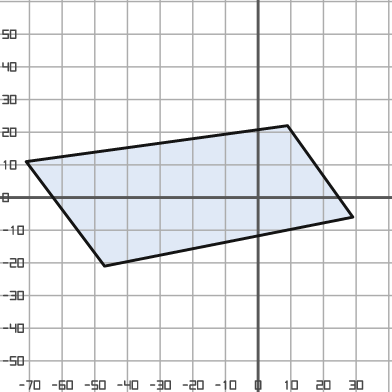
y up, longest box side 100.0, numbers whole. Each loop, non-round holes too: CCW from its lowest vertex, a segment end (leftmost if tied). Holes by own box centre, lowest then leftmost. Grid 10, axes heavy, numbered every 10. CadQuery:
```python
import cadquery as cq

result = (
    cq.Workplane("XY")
    .moveTo(-47.0, -21.0)
    .lineTo(29.0, -6.0)
    .lineTo(9.0, 22.0)
    .lineTo(-71.0, 11.0)
    .close()
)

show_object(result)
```